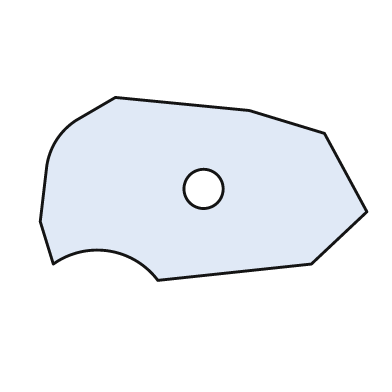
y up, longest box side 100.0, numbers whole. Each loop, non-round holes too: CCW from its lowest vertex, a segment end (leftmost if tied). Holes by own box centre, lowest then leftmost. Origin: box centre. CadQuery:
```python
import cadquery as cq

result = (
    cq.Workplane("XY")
    .moveTo(-14.0, -28.0)
    .lineTo(33.0, -23.0)
    .lineTo(50.0, -7.0)
    .lineTo(37.0, 17.0)
    .lineTo(14.0, 24.0)
    .lineTo(-27.0, 28.0)
    .lineTo(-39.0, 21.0)
    .threePointArc((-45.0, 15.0), (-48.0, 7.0))
    .lineTo(-50.0, -10.0)
    .lineTo(-46.0, -23.0)
    .threePointArc((-29.0, -19.0), (-14.0, -28.0))
    .close()
    .moveTo(0.0, 0.0)
    .circle(6.0)
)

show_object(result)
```